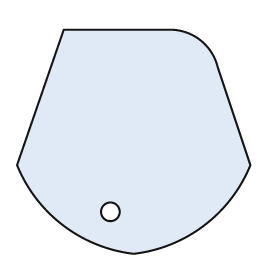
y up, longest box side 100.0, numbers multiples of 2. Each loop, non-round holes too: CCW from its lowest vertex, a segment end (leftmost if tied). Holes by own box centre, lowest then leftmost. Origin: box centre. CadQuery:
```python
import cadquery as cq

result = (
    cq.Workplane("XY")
    .moveTo(0.0, -48.0)
    .threePointArc((30.0, -36.0), (50.0, -10.0))
    .lineTo(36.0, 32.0)
    .threePointArc((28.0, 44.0), (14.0, 48.0))
    .lineTo(-30.0, 48.0)
    .lineTo(-50.0, -10.0)
    .threePointArc((-30.0, -36.0), (0.0, -48.0))
    .close()
    .moveTo(-10.0, -30.0)
    .circle(4.0)
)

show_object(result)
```